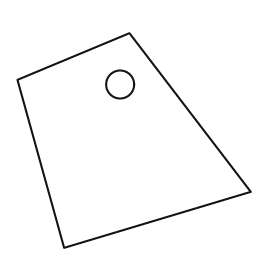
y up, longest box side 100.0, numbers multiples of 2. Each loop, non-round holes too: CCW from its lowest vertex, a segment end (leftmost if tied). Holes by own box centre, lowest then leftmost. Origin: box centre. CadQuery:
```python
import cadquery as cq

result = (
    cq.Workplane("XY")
    .moveTo(-30.0, -46.0)
    .lineTo(50.0, -22.0)
    .lineTo(-2.0, 46.0)
    .lineTo(-50.0, 26.0)
    .close()
    .moveTo(-6.0, 24.0)
    .circle(6.0)
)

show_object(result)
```